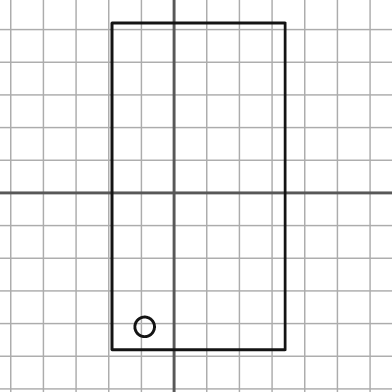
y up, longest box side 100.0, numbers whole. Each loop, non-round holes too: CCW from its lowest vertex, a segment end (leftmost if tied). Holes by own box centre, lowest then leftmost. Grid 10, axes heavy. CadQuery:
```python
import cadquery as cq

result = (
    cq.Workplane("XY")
    .moveTo(-19.0, -48.0)
    .lineTo(34.0, -48.0)
    .lineTo(34.0, 52.0)
    .lineTo(-19.0, 52.0)
    .close()
    .moveTo(-9.0, -41.0)
    .circle(3.0)
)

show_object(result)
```